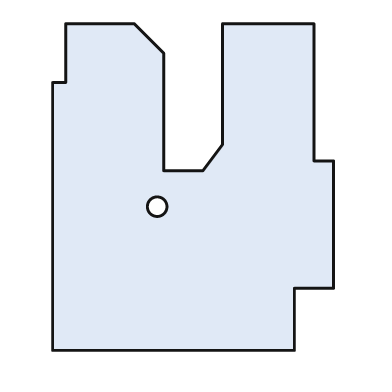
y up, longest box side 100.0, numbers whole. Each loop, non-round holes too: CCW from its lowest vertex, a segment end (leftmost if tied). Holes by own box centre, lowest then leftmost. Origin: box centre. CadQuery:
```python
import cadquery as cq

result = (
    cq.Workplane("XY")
    .moveTo(-43.0, -50.0)
    .lineTo(31.0, -50.0)
    .lineTo(31.0, -31.0)
    .lineTo(43.0, -31.0)
    .lineTo(43.0, 8.0)
    .lineTo(37.0, 8.0)
    .lineTo(37.0, 50.0)
    .lineTo(9.0, 50.0)
    .lineTo(9.0, 13.0)
    .lineTo(3.0, 5.0)
    .lineTo(-9.0, 5.0)
    .lineTo(-9.0, 41.0)
    .lineTo(-18.0, 50.0)
    .lineTo(-39.0, 50.0)
    .lineTo(-39.0, 32.0)
    .lineTo(-43.0, 32.0)
    .close()
    .moveTo(-11.0, -6.0)
    .circle(3.0)
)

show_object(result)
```